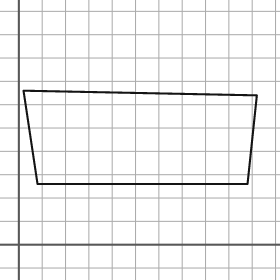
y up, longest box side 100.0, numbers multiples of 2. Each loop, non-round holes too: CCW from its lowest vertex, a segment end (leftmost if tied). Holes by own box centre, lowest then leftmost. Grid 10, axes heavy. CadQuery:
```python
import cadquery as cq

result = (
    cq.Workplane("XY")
    .moveTo(8.0, 26.0)
    .lineTo(98.0, 26.0)
    .lineTo(102.0, 64.0)
    .lineTo(2.0, 66.0)
    .close()
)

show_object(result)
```